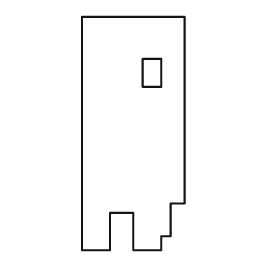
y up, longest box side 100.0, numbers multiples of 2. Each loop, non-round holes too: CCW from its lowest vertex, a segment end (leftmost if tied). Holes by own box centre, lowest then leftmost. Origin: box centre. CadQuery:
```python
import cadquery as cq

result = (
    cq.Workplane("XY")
    .moveTo(-22.0, -50.0)
    .lineTo(-10.0, -50.0)
    .lineTo(-10.0, -34.0)
    .lineTo(0.0, -34.0)
    .lineTo(0.0, -50.0)
    .lineTo(12.0, -50.0)
    .lineTo(12.0, -44.0)
    .lineTo(16.0, -44.0)
    .lineTo(16.0, -30.0)
    .lineTo(22.0, -30.0)
    .lineTo(22.0, 50.0)
    .lineTo(-22.0, 50.0)
    .close()
    .moveTo(4.0, 20.0)
    .lineTo(12.0, 20.0)
    .lineTo(12.0, 32.0)
    .lineTo(4.0, 32.0)
    .close()
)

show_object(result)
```